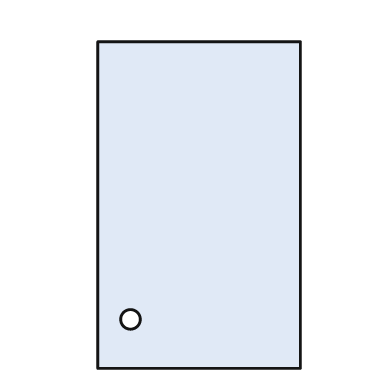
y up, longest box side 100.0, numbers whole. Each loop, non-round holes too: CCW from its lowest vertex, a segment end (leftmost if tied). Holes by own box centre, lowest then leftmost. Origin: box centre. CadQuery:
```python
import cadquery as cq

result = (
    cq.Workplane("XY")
    .moveTo(-31.0, -50.0)
    .lineTo(31.0, -50.0)
    .lineTo(31.0, 50.0)
    .lineTo(-31.0, 50.0)
    .close()
    .moveTo(-21.0, -35.0)
    .circle(3.0)
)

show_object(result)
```